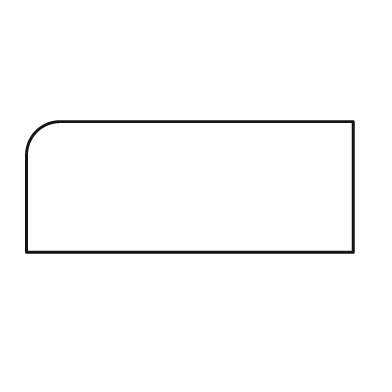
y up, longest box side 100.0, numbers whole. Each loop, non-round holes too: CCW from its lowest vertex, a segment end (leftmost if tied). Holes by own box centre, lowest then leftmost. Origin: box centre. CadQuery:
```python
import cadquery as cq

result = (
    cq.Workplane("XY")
    .moveTo(-50.0, -20.0)
    .lineTo(50.0, -20.0)
    .lineTo(50.0, 20.0)
    .lineTo(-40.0, 20.0)
    .threePointArc((-47.0, 17.0), (-50.0, 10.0))
    .close()
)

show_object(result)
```